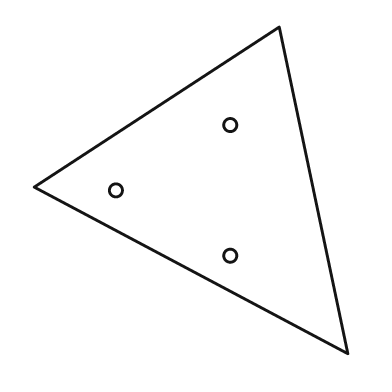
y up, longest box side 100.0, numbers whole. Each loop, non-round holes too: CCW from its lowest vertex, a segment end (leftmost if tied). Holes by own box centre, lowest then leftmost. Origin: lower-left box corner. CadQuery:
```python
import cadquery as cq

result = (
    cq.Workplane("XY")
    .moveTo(96.0, 0.0)
    .lineTo(75.0, 100.0)
    .lineTo(0.0, 51.0)
    .close()
    .moveTo(60.0, 30.0)
    .circle(2.0)
    .moveTo(25.0, 50.0)
    .circle(2.0)
    .moveTo(60.0, 70.0)
    .circle(2.0)
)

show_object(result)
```